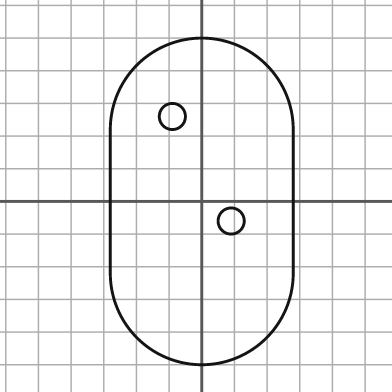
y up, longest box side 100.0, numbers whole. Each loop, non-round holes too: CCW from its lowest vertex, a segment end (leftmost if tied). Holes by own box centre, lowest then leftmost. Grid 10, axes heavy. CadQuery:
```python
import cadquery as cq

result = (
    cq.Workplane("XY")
    .moveTo(-28.0, -22.0)
    .threePointArc((0.0, -50.0), (28.0, -22.0))
    .lineTo(28.0, 22.0)
    .threePointArc((0.0, 50.0), (-28.0, 22.0))
    .close()
    .moveTo(9.0, -6.0)
    .circle(4.0)
    .moveTo(-9.0, 26.0)
    .circle(4.0)
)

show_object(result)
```